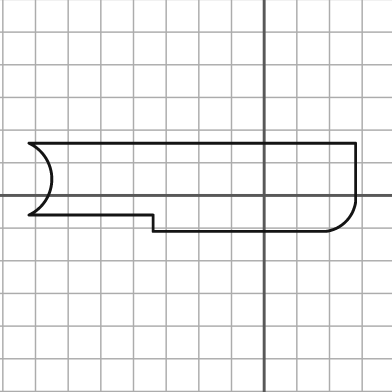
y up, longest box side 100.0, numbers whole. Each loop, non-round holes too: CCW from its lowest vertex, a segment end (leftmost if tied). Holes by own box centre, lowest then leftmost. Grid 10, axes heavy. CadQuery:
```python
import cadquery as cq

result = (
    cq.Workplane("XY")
    .moveTo(-34.0, -11.0)
    .lineTo(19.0, -11.0)
    .threePointArc((25.0, -8.0), (28.0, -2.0))
    .lineTo(28.0, 16.0)
    .lineTo(-72.0, 16.0)
    .threePointArc((-65.0, 5.0), (-72.0, -6.0))
    .lineTo(-34.0, -6.0)
    .close()
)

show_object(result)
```